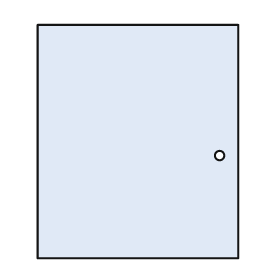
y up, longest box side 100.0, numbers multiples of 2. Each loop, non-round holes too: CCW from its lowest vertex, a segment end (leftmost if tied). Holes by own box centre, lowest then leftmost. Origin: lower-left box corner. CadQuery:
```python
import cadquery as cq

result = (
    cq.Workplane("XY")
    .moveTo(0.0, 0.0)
    .lineTo(86.0, 0.0)
    .lineTo(86.0, 100.0)
    .lineTo(0.0, 100.0)
    .close()
    .moveTo(78.0, 44.0)
    .circle(2.0)
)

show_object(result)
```